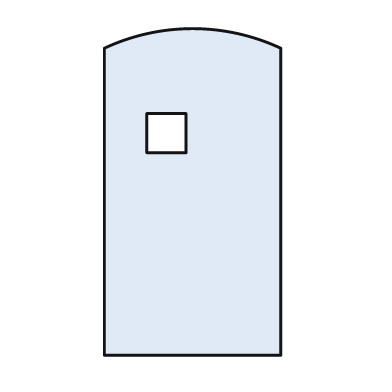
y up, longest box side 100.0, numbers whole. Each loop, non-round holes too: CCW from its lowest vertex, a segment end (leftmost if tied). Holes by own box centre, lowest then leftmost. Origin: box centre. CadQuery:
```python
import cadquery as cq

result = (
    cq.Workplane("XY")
    .moveTo(-27.0, -50.0)
    .lineTo(27.0, -50.0)
    .lineTo(27.0, 44.0)
    .threePointArc((0.0, 50.0), (-27.0, 44.0))
    .close()
    .moveTo(-14.0, 12.0)
    .lineTo(-2.0, 12.0)
    .lineTo(-2.0, 24.0)
    .lineTo(-14.0, 24.0)
    .close()
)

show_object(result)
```